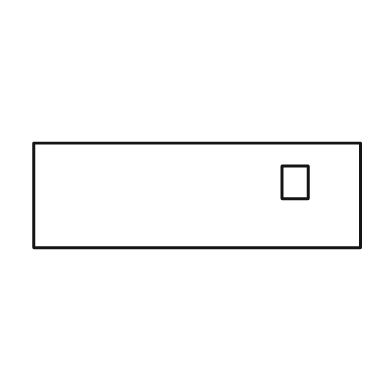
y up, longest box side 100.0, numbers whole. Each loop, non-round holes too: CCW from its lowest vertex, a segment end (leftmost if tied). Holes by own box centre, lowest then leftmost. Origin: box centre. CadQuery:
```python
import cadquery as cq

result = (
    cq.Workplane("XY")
    .moveTo(-50.0, -16.0)
    .lineTo(50.0, -16.0)
    .lineTo(50.0, 16.0)
    .lineTo(-50.0, 16.0)
    .close()
    .moveTo(26.0, -1.0)
    .lineTo(34.0, -1.0)
    .lineTo(34.0, 9.0)
    .lineTo(26.0, 9.0)
    .close()
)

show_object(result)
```